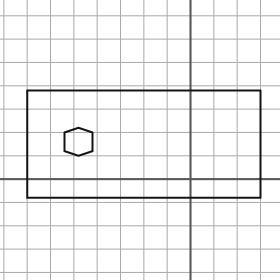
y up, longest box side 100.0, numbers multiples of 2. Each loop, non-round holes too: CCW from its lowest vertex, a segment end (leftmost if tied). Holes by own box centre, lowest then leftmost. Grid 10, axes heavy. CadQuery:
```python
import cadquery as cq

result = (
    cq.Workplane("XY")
    .moveTo(-70.0, -8.0)
    .lineTo(30.0, -8.0)
    .lineTo(30.0, 38.0)
    .lineTo(-70.0, 38.0)
    .close()
    .moveTo(-48.0, 10.0)
    .lineTo(-42.0, 12.0)
    .lineTo(-42.0, 20.0)
    .lineTo(-48.0, 22.0)
    .lineTo(-54.0, 20.0)
    .lineTo(-54.0, 12.0)
    .close()
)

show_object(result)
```